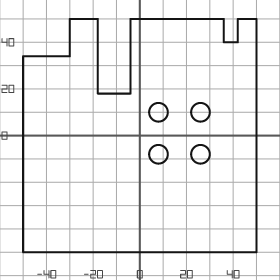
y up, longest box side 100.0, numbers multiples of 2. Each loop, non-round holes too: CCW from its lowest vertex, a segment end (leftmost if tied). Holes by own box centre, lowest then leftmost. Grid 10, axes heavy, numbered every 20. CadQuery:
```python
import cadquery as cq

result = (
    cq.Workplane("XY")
    .moveTo(-50.0, -50.0)
    .lineTo(50.0, -50.0)
    .lineTo(50.0, 50.0)
    .lineTo(42.0, 50.0)
    .lineTo(42.0, 40.0)
    .lineTo(36.0, 40.0)
    .lineTo(36.0, 50.0)
    .lineTo(-4.0, 50.0)
    .lineTo(-4.0, 18.0)
    .lineTo(-18.0, 18.0)
    .lineTo(-18.0, 50.0)
    .lineTo(-30.0, 50.0)
    .lineTo(-30.0, 34.0)
    .lineTo(-50.0, 34.0)
    .close()
    .moveTo(8.0, -8.0)
    .circle(4.0)
    .moveTo(26.0, -8.0)
    .circle(4.0)
    .moveTo(8.0, 10.0)
    .circle(4.0)
    .moveTo(26.0, 10.0)
    .circle(4.0)
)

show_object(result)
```